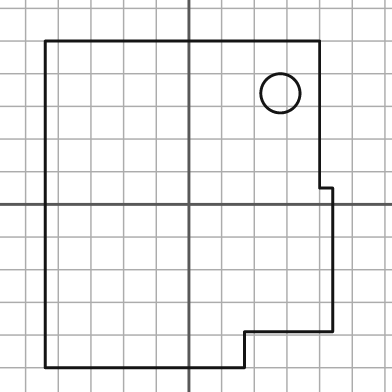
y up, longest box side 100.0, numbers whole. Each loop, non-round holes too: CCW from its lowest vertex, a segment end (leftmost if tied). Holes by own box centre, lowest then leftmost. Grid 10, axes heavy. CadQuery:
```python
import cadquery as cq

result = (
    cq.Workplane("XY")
    .moveTo(-44.0, -50.0)
    .lineTo(17.0, -50.0)
    .lineTo(17.0, -39.0)
    .lineTo(44.0, -39.0)
    .lineTo(44.0, 5.0)
    .lineTo(40.0, 5.0)
    .lineTo(40.0, 50.0)
    .lineTo(-44.0, 50.0)
    .close()
    .moveTo(28.0, 34.0)
    .circle(6.0)
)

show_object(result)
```